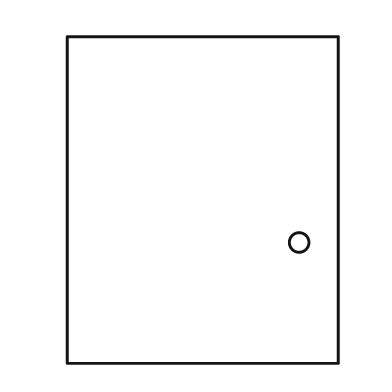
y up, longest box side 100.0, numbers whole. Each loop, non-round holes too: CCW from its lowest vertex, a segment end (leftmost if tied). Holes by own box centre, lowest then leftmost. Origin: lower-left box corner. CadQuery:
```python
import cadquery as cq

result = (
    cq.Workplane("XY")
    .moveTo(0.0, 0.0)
    .lineTo(83.0, 0.0)
    .lineTo(83.0, 100.0)
    .lineTo(0.0, 100.0)
    .close()
    .moveTo(71.0, 37.0)
    .circle(3.0)
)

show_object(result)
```